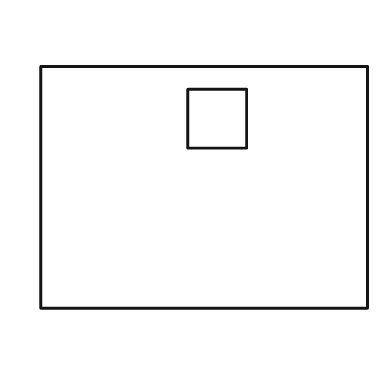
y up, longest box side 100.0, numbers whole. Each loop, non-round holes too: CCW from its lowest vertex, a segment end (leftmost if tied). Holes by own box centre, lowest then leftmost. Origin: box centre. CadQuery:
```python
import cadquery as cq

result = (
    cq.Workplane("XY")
    .moveTo(-50.0, -37.0)
    .lineTo(50.0, -37.0)
    .lineTo(50.0, 37.0)
    .lineTo(-50.0, 37.0)
    .close()
    .moveTo(-5.0, 12.0)
    .lineTo(13.0, 12.0)
    .lineTo(13.0, 30.0)
    .lineTo(-5.0, 30.0)
    .close()
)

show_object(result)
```